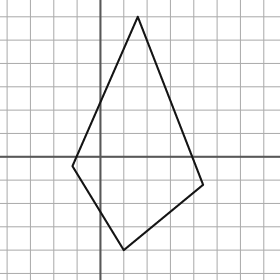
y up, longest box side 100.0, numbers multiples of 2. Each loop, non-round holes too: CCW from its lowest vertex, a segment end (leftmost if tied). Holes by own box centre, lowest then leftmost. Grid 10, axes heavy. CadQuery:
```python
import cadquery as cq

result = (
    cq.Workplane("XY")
    .moveTo(10.0, -40.0)
    .lineTo(44.0, -12.0)
    .lineTo(16.0, 60.0)
    .lineTo(-12.0, -4.0)
    .close()
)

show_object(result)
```